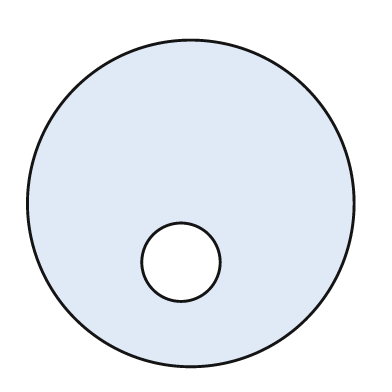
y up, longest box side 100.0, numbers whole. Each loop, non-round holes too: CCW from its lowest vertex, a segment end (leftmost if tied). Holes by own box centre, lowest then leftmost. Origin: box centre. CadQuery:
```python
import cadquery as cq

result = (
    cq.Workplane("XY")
    .moveTo(0.0, 0.0)
    .circle(50.0)
    .moveTo(-3.0, -18.0)
    .circle(12.0)
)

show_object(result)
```